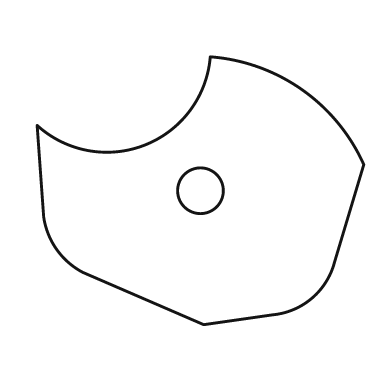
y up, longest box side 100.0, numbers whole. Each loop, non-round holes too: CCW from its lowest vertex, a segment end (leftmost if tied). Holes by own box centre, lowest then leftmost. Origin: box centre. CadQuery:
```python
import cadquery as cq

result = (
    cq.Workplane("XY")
    .moveTo(1.0, -41.0)
    .lineTo(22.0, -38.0)
    .threePointArc((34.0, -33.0), (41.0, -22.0))
    .lineTo(50.0, 8.0)
    .threePointArc((31.0, 31.0), (3.0, 41.0))
    .threePointArc((-17.0, 14.0), (-50.0, 20.0))
    .lineTo(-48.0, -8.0)
    .threePointArc((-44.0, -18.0), (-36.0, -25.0))
    .close()
    .moveTo(0.0, 0.0)
    .circle(7.0)
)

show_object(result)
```